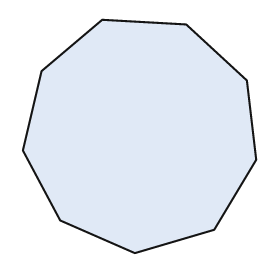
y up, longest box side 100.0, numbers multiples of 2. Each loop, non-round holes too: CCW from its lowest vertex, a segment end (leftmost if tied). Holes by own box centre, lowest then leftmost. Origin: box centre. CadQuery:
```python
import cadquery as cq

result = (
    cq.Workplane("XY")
    .moveTo(-2.0, -50.0)
    .lineTo(32.0, -40.0)
    .lineTo(50.0, -10.0)
    .lineTo(46.0, 24.0)
    .lineTo(20.0, 48.0)
    .lineTo(-16.0, 50.0)
    .lineTo(-42.0, 28.0)
    .lineTo(-50.0, -6.0)
    .lineTo(-34.0, -36.0)
    .close()
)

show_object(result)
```